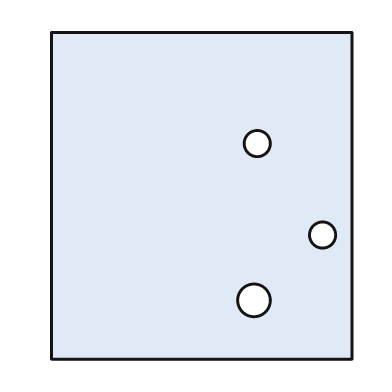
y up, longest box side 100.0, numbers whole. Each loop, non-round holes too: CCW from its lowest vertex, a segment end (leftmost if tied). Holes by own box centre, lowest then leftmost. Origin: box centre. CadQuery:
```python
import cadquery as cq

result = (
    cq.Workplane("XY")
    .moveTo(-46.0, -50.0)
    .lineTo(46.0, -50.0)
    .lineTo(46.0, 50.0)
    .lineTo(-46.0, 50.0)
    .close()
    .moveTo(16.0, -32.0)
    .circle(5.0)
    .moveTo(37.0, -12.0)
    .circle(4.0)
    .moveTo(17.0, 16.0)
    .circle(4.0)
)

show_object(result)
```